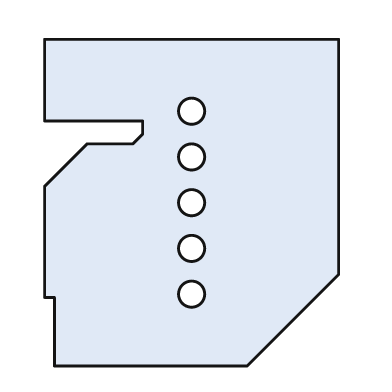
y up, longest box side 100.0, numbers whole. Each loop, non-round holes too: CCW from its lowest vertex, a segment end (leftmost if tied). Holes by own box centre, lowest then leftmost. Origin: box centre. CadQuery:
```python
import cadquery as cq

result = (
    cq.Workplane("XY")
    .moveTo(-42.0, -50.0)
    .lineTo(17.0, -50.0)
    .lineTo(45.0, -22.0)
    .lineTo(45.0, 50.0)
    .lineTo(-45.0, 50.0)
    .lineTo(-45.0, 25.0)
    .lineTo(-15.0, 25.0)
    .lineTo(-15.0, 21.0)
    .lineTo(-18.0, 18.0)
    .lineTo(-32.0, 18.0)
    .lineTo(-45.0, 5.0)
    .lineTo(-45.0, -29.0)
    .lineTo(-42.0, -29.0)
    .close()
    .moveTo(0.0, -28.0)
    .circle(4.0)
    .moveTo(0.0, -14.0)
    .circle(4.0)
    .moveTo(0.0, 0.0)
    .circle(4.0)
    .moveTo(0.0, 14.0)
    .circle(4.0)
    .moveTo(0.0, 28.0)
    .circle(4.0)
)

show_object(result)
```